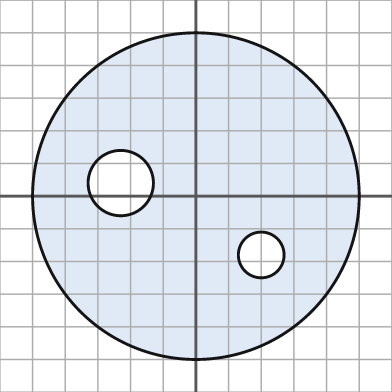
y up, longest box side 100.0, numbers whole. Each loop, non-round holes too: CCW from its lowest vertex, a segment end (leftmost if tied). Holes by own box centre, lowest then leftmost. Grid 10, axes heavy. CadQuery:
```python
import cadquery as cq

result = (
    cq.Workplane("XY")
    .moveTo(0.0, 0.0)
    .circle(50.0)
    .moveTo(20.0, -18.0)
    .circle(7.0)
    .moveTo(-23.0, 4.0)
    .circle(10.0)
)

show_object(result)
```